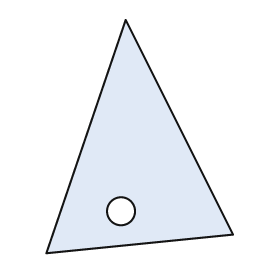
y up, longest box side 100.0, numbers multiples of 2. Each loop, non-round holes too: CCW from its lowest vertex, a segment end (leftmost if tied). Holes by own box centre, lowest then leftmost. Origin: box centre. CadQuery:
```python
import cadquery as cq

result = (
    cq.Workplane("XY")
    .moveTo(-40.0, -50.0)
    .lineTo(40.0, -42.0)
    .lineTo(-6.0, 50.0)
    .close()
    .moveTo(-8.0, -32.0)
    .circle(6.0)
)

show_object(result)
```